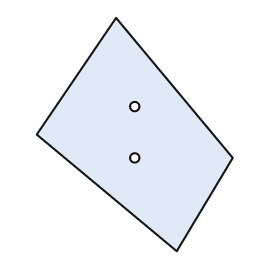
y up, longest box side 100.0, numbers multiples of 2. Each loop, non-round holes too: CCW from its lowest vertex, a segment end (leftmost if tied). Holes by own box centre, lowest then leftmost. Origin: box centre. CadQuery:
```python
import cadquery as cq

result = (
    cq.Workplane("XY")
    .moveTo(18.0, -50.0)
    .lineTo(42.0, -10.0)
    .lineTo(-8.0, 50.0)
    .lineTo(-42.0, 0.0)
    .close()
    .moveTo(0.0, -10.0)
    .circle(2.0)
    .moveTo(0.0, 12.0)
    .circle(2.0)
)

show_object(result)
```